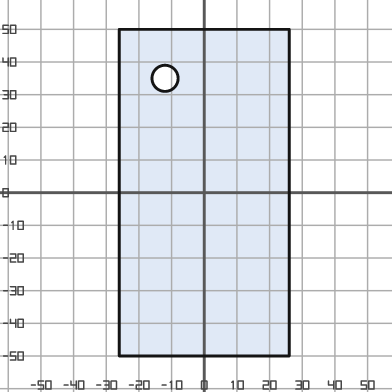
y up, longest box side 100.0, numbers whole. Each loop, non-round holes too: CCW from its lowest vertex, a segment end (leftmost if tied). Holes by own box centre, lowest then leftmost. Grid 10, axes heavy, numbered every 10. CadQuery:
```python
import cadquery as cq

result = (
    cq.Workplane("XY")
    .moveTo(-26.0, -50.0)
    .lineTo(26.0, -50.0)
    .lineTo(26.0, 50.0)
    .lineTo(-26.0, 50.0)
    .close()
    .moveTo(-12.0, 35.0)
    .circle(4.0)
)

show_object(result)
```